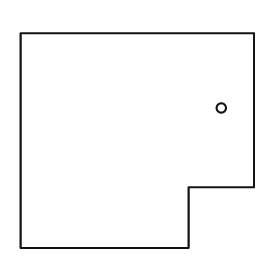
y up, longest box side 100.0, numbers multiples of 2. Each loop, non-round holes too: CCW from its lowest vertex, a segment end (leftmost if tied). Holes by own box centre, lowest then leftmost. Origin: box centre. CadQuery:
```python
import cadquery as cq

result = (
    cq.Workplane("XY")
    .moveTo(-50.0, -46.0)
    .lineTo(22.0, -46.0)
    .lineTo(22.0, -20.0)
    .lineTo(50.0, -20.0)
    .lineTo(50.0, 46.0)
    .lineTo(-50.0, 46.0)
    .close()
    .moveTo(36.0, 14.0)
    .circle(2.0)
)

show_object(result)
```